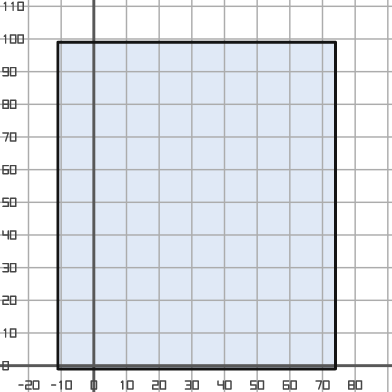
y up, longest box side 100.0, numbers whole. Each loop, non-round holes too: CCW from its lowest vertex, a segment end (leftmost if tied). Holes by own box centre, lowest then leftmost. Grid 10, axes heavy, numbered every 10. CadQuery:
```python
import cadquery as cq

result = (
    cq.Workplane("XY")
    .moveTo(-11.0, -1.0)
    .lineTo(74.0, -1.0)
    .lineTo(74.0, 99.0)
    .lineTo(-11.0, 99.0)
    .close()
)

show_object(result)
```